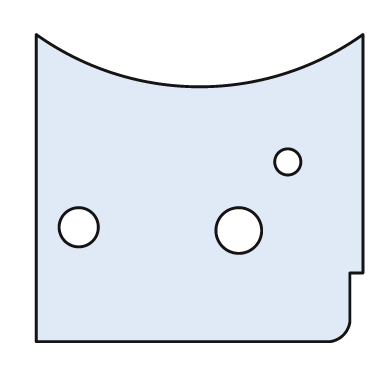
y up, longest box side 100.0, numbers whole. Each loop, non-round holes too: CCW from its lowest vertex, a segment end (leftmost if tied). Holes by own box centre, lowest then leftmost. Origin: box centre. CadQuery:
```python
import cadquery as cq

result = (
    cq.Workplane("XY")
    .moveTo(-50.0, -47.0)
    .lineTo(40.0, -47.0)
    .threePointArc((44.0, -45.0), (46.0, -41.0))
    .lineTo(46.0, -26.0)
    .lineTo(50.0, -26.0)
    .lineTo(50.0, 47.0)
    .threePointArc((0.0, 31.0), (-50.0, 47.0))
    .close()
    .moveTo(12.0, -13.0)
    .circle(7.0)
    .moveTo(-37.0, -12.0)
    .circle(6.0)
    .moveTo(27.0, 8.0)
    .circle(4.0)
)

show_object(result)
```